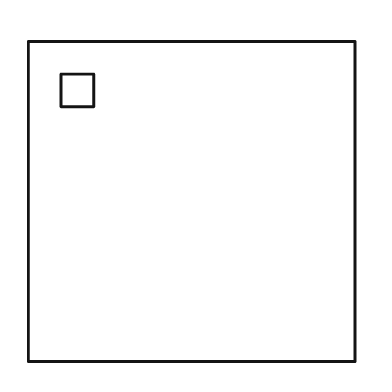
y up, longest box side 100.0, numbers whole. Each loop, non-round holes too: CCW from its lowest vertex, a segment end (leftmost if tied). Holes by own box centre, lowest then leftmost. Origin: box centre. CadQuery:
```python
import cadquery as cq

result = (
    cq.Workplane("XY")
    .moveTo(-50.0, -49.0)
    .lineTo(50.0, -49.0)
    .lineTo(50.0, 49.0)
    .lineTo(-50.0, 49.0)
    .close()
    .moveTo(-40.0, 29.0)
    .lineTo(-30.0, 29.0)
    .lineTo(-30.0, 39.0)
    .lineTo(-40.0, 39.0)
    .close()
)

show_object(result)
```